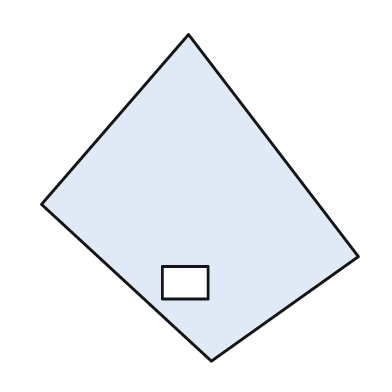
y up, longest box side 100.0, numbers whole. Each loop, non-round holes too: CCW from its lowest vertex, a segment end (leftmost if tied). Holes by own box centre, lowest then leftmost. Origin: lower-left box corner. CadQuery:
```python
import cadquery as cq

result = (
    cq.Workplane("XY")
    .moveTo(52.0, 0.0)
    .lineTo(97.0, 32.0)
    .lineTo(45.0, 100.0)
    .lineTo(0.0, 48.0)
    .close()
    .moveTo(37.0, 19.0)
    .lineTo(51.0, 19.0)
    .lineTo(51.0, 29.0)
    .lineTo(37.0, 29.0)
    .close()
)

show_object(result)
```